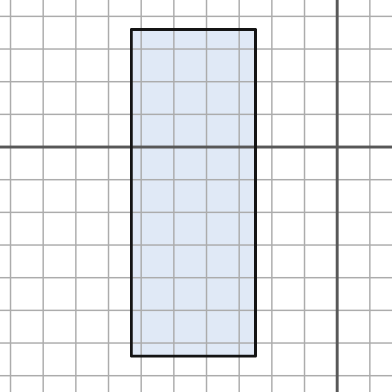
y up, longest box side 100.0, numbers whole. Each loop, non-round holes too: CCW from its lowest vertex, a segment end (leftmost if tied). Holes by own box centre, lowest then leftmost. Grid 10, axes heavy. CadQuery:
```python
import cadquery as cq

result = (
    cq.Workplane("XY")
    .moveTo(-63.0, -64.0)
    .lineTo(-25.0, -64.0)
    .lineTo(-25.0, 36.0)
    .lineTo(-63.0, 36.0)
    .close()
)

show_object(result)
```